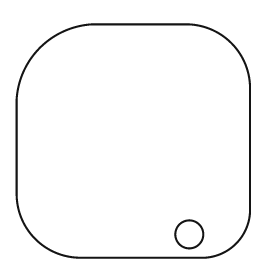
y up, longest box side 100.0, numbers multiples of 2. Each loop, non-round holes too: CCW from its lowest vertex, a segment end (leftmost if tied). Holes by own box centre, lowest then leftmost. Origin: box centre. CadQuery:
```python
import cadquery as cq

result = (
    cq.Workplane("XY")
    .moveTo(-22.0, -50.0)
    .lineTo(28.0, -50.0)
    .threePointArc((44.0, -44.0), (50.0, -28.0))
    .lineTo(50.0, 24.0)
    .threePointArc((42.0, 42.0), (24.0, 50.0))
    .lineTo(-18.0, 50.0)
    .threePointArc((-40.0, 40.0), (-50.0, 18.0))
    .lineTo(-50.0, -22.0)
    .threePointArc((-42.0, -42.0), (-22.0, -50.0))
    .close()
    .moveTo(24.0, -40.0)
    .circle(6.0)
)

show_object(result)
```